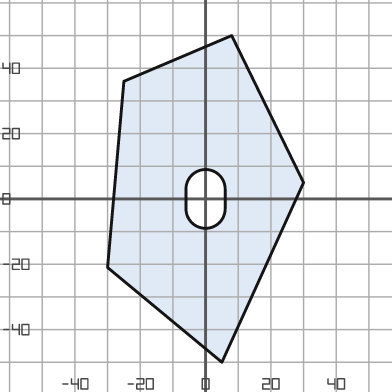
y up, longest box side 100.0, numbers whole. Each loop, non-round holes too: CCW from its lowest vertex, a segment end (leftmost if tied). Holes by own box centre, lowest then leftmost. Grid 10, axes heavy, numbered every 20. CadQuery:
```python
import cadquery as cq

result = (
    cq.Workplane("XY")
    .moveTo(5.0, -50.0)
    .lineTo(30.0, 5.0)
    .lineTo(8.0, 50.0)
    .lineTo(-25.0, 36.0)
    .lineTo(-30.0, -21.0)
    .close()
    .moveTo(-6.0, -3.0)
    .threePointArc((0.0, -9.0), (6.0, -3.0))
    .lineTo(6.0, 3.0)
    .threePointArc((0.0, 9.0), (-6.0, 3.0))
    .close()
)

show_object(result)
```